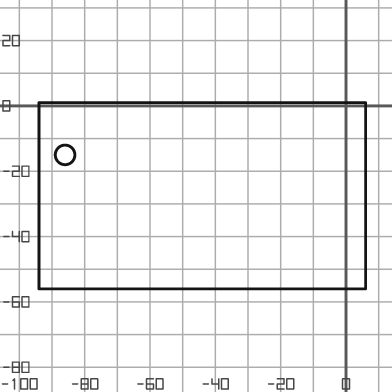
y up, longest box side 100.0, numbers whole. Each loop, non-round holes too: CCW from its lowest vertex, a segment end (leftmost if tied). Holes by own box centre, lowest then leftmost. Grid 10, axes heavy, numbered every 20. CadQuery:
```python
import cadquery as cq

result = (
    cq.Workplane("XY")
    .moveTo(-94.0, -56.0)
    .lineTo(6.0, -56.0)
    .lineTo(6.0, 1.0)
    .lineTo(-94.0, 1.0)
    .close()
    .moveTo(-86.0, -15.0)
    .circle(3.0)
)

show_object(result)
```